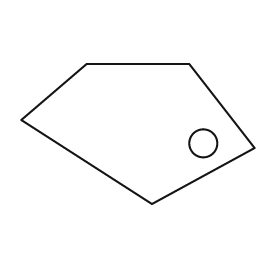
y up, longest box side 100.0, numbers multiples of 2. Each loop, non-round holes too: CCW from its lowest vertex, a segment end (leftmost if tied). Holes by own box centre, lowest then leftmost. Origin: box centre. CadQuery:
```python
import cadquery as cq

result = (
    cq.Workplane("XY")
    .moveTo(6.0, -30.0)
    .lineTo(50.0, -6.0)
    .lineTo(22.0, 30.0)
    .lineTo(-22.0, 30.0)
    .lineTo(-50.0, 6.0)
    .close()
    .moveTo(28.0, -4.0)
    .circle(6.0)
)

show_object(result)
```